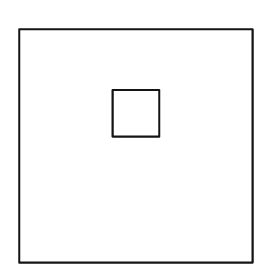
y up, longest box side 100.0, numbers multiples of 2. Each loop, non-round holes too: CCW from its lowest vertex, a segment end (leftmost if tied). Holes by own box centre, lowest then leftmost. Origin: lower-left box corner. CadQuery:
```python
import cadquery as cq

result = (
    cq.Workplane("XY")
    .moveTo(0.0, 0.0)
    .lineTo(100.0, 0.0)
    .lineTo(100.0, 100.0)
    .lineTo(0.0, 100.0)
    .close()
    .moveTo(40.0, 54.0)
    .lineTo(60.0, 54.0)
    .lineTo(60.0, 74.0)
    .lineTo(40.0, 74.0)
    .close()
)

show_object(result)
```